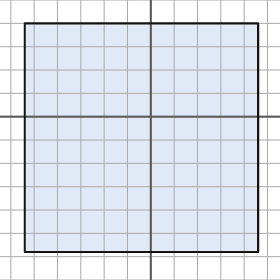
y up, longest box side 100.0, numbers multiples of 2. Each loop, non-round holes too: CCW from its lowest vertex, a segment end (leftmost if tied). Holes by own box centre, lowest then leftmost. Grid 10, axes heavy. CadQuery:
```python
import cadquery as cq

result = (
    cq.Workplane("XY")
    .moveTo(-54.0, -58.0)
    .lineTo(46.0, -58.0)
    .lineTo(46.0, 40.0)
    .lineTo(-54.0, 40.0)
    .close()
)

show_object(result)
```